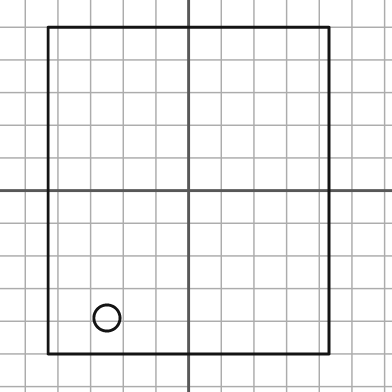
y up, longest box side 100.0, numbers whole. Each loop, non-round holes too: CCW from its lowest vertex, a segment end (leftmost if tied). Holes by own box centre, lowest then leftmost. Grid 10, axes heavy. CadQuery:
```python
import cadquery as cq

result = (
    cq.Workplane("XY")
    .moveTo(-43.0, -50.0)
    .lineTo(43.0, -50.0)
    .lineTo(43.0, 50.0)
    .lineTo(-43.0, 50.0)
    .close()
    .moveTo(-25.0, -39.0)
    .circle(4.0)
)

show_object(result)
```